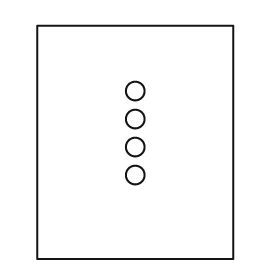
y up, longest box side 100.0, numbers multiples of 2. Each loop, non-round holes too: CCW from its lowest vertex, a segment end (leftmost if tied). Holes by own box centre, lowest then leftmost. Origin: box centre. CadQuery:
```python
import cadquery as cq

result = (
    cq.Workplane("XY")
    .moveTo(-42.0, -50.0)
    .lineTo(42.0, -50.0)
    .lineTo(42.0, 50.0)
    .lineTo(-42.0, 50.0)
    .close()
    .moveTo(0.0, -14.0)
    .circle(4.0)
    .moveTo(0.0, -2.0)
    .circle(4.0)
    .moveTo(0.0, 10.0)
    .circle(4.0)
    .moveTo(0.0, 22.0)
    .circle(4.0)
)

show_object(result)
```